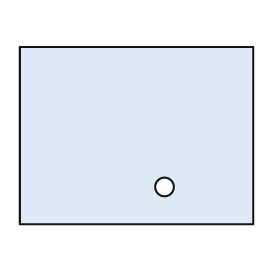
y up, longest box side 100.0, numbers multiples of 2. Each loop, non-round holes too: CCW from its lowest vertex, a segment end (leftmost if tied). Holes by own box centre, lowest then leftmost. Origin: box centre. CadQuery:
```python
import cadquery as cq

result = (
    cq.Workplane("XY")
    .moveTo(-50.0, -38.0)
    .lineTo(50.0, -38.0)
    .lineTo(50.0, 38.0)
    .lineTo(-50.0, 38.0)
    .close()
    .moveTo(12.0, -22.0)
    .circle(4.0)
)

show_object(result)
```